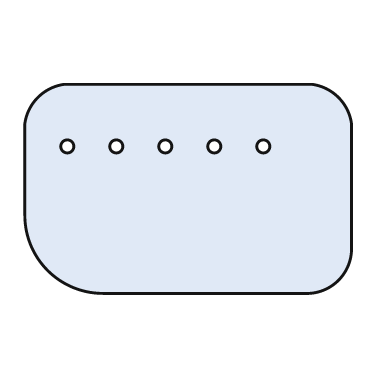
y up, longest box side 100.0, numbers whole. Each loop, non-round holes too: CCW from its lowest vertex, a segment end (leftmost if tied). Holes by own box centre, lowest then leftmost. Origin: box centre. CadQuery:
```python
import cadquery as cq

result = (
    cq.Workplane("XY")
    .moveTo(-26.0, -32.0)
    .lineTo(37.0, -32.0)
    .threePointArc((46.0, -28.0), (50.0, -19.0))
    .lineTo(50.0, 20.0)
    .threePointArc((46.0, 28.0), (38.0, 32.0))
    .lineTo(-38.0, 32.0)
    .threePointArc((-46.0, 28.0), (-50.0, 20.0))
    .lineTo(-50.0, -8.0)
    .threePointArc((-43.0, -25.0), (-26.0, -32.0))
    .close()
    .moveTo(-37.0, 13.0)
    .circle(2.0)
    .moveTo(-22.0, 13.0)
    .circle(2.0)
    .moveTo(-7.0, 13.0)
    .circle(2.0)
    .moveTo(8.0, 13.0)
    .circle(2.0)
    .moveTo(23.0, 13.0)
    .circle(2.0)
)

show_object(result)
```